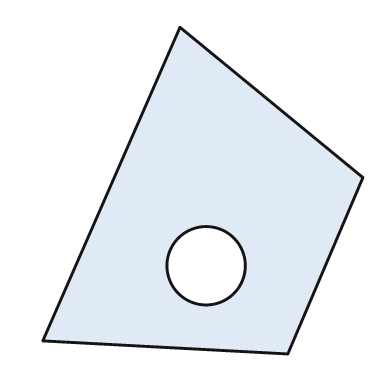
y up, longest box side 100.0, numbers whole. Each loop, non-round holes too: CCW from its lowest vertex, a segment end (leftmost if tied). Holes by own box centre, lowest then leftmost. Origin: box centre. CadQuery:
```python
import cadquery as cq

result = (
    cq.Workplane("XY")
    .moveTo(26.0, -50.0)
    .lineTo(49.0, 4.0)
    .lineTo(-7.0, 50.0)
    .lineTo(-49.0, -46.0)
    .close()
    .moveTo(1.0, -23.0)
    .circle(12.0)
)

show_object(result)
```